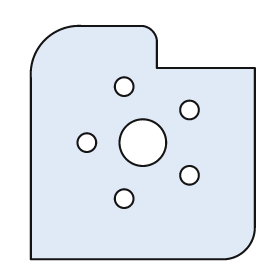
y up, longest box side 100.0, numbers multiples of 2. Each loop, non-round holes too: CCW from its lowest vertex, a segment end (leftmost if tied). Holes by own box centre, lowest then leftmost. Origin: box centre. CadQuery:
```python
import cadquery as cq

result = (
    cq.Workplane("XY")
    .moveTo(-48.0, -50.0)
    .lineTo(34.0, -50.0)
    .threePointArc((44.0, -46.0), (48.0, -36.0))
    .lineTo(48.0, 32.0)
    .lineTo(6.0, 32.0)
    .lineTo(6.0, 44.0)
    .threePointArc((4.0, 48.0), (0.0, 50.0))
    .lineTo(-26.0, 50.0)
    .threePointArc((-42.0, 44.0), (-48.0, 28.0))
    .close()
    .moveTo(-8.0, -24.0)
    .circle(4.0)
    .moveTo(20.0, -14.0)
    .circle(4.0)
    .moveTo(-24.0, 0.0)
    .circle(4.0)
    .moveTo(0.0, 0.0)
    .circle(10.0)
    .moveTo(20.0, 14.0)
    .circle(4.0)
    .moveTo(-8.0, 24.0)
    .circle(4.0)
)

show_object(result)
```